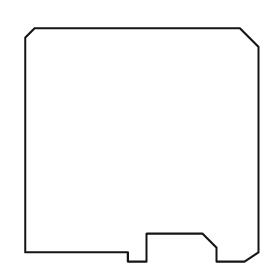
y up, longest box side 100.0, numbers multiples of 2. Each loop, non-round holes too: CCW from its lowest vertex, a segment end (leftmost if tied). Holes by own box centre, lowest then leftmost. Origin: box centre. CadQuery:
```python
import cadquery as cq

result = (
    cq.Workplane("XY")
    .moveTo(-6.0, -50.0)
    .lineTo(2.0, -50.0)
    .lineTo(2.0, -38.0)
    .lineTo(26.0, -38.0)
    .lineTo(32.0, -44.0)
    .lineTo(32.0, -50.0)
    .lineTo(44.0, -50.0)
    .lineTo(50.0, -46.0)
    .lineTo(50.0, 42.0)
    .lineTo(42.0, 50.0)
    .lineTo(-46.0, 50.0)
    .lineTo(-50.0, 46.0)
    .lineTo(-50.0, -46.0)
    .lineTo(-6.0, -46.0)
    .close()
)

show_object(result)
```